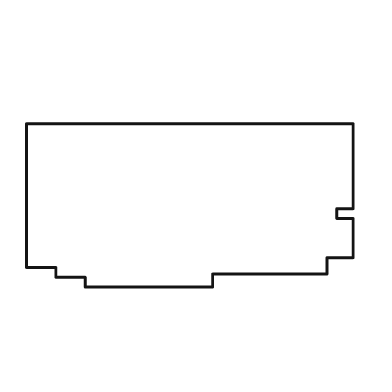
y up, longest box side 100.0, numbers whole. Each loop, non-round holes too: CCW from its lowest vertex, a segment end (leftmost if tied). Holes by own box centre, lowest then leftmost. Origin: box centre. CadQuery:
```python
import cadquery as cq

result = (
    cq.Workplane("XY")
    .moveTo(-32.0, -25.0)
    .lineTo(7.0, -25.0)
    .lineTo(7.0, -21.0)
    .lineTo(42.0, -21.0)
    .lineTo(42.0, -16.0)
    .lineTo(50.0, -16.0)
    .lineTo(50.0, -4.0)
    .lineTo(45.0, -4.0)
    .lineTo(45.0, -1.0)
    .lineTo(50.0, -1.0)
    .lineTo(50.0, 25.0)
    .lineTo(-50.0, 25.0)
    .lineTo(-50.0, -19.0)
    .lineTo(-41.0, -19.0)
    .lineTo(-41.0, -22.0)
    .lineTo(-32.0, -22.0)
    .close()
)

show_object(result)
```